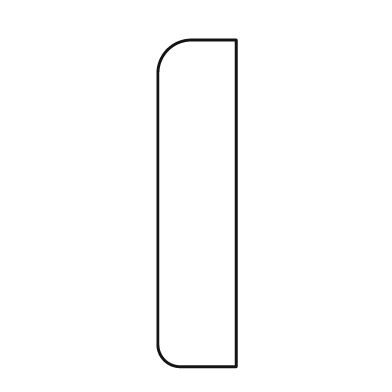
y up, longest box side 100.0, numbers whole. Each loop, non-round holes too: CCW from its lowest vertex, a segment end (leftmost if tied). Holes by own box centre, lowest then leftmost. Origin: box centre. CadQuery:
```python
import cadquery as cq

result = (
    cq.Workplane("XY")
    .moveTo(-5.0, -50.0)
    .lineTo(12.0, -50.0)
    .lineTo(12.0, 50.0)
    .lineTo(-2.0, 50.0)
    .threePointArc((-9.0, 47.0), (-12.0, 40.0))
    .lineTo(-12.0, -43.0)
    .threePointArc((-10.0, -48.0), (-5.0, -50.0))
    .close()
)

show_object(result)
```